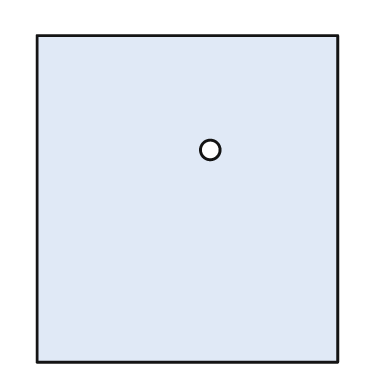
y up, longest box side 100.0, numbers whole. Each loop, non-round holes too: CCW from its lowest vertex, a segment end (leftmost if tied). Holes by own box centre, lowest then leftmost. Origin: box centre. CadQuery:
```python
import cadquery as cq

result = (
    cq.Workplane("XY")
    .moveTo(-46.0, -50.0)
    .lineTo(46.0, -50.0)
    .lineTo(46.0, 50.0)
    .lineTo(-46.0, 50.0)
    .close()
    .moveTo(7.0, 15.0)
    .circle(3.0)
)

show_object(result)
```